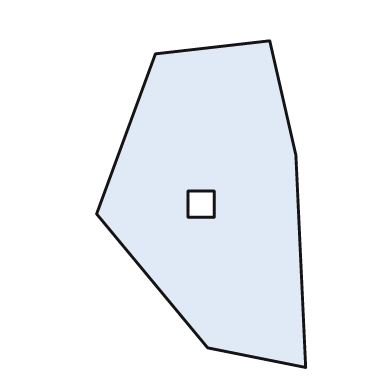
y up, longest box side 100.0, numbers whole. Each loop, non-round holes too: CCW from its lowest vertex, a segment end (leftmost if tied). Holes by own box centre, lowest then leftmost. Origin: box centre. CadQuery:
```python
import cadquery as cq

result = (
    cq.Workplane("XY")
    .moveTo(32.0, -50.0)
    .lineTo(29.0, 15.0)
    .lineTo(21.0, 50.0)
    .lineTo(-14.0, 46.0)
    .lineTo(-32.0, -3.0)
    .lineTo(2.0, -44.0)
    .close()
    .moveTo(-4.0, -4.0)
    .lineTo(4.0, -4.0)
    .lineTo(4.0, 4.0)
    .lineTo(-4.0, 4.0)
    .close()
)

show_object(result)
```